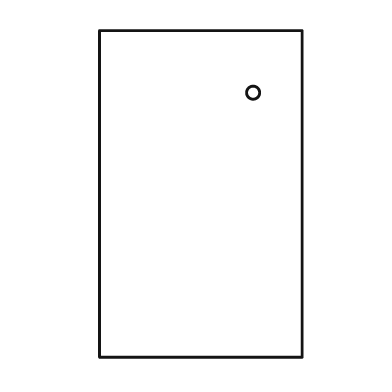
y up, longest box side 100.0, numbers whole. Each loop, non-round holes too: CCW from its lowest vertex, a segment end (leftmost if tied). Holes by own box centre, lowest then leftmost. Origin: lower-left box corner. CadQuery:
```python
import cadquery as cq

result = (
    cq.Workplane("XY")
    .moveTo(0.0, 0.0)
    .lineTo(62.0, 0.0)
    .lineTo(62.0, 100.0)
    .lineTo(0.0, 100.0)
    .close()
    .moveTo(47.0, 81.0)
    .circle(2.0)
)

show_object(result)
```